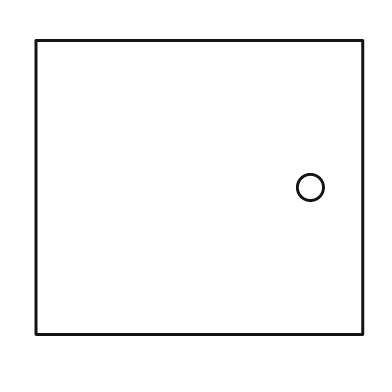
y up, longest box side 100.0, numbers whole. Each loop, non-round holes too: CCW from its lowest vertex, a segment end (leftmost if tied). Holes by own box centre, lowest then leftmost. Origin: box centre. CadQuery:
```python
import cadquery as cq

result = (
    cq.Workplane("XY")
    .moveTo(-50.0, -45.0)
    .lineTo(50.0, -45.0)
    .lineTo(50.0, 45.0)
    .lineTo(-50.0, 45.0)
    .close()
    .moveTo(34.0, 0.0)
    .circle(4.0)
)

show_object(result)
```